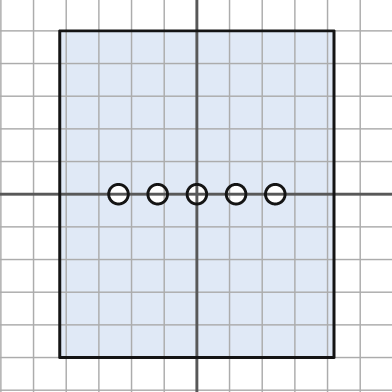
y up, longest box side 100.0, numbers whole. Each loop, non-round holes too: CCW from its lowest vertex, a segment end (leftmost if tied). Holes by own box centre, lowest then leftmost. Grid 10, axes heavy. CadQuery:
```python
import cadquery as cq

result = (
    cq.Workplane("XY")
    .moveTo(-42.0, -50.0)
    .lineTo(42.0, -50.0)
    .lineTo(42.0, 50.0)
    .lineTo(-42.0, 50.0)
    .close()
    .moveTo(-24.0, 0.0)
    .circle(3.0)
    .moveTo(-12.0, 0.0)
    .circle(3.0)
    .moveTo(0.0, 0.0)
    .circle(3.0)
    .moveTo(12.0, 0.0)
    .circle(3.0)
    .moveTo(24.0, 0.0)
    .circle(3.0)
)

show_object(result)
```